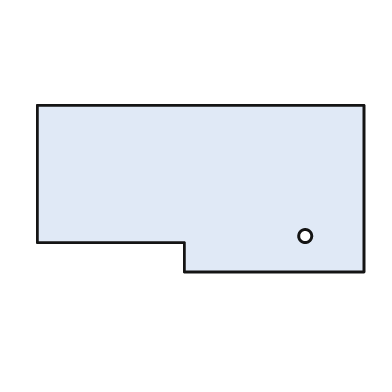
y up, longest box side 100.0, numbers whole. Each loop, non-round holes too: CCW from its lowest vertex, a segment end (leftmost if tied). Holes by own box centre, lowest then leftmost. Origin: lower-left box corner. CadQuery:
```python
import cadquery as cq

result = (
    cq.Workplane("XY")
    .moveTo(45.0, 0.0)
    .lineTo(100.0, 0.0)
    .lineTo(100.0, 51.0)
    .lineTo(0.0, 51.0)
    .lineTo(0.0, 9.0)
    .lineTo(45.0, 9.0)
    .close()
    .moveTo(82.0, 11.0)
    .circle(2.0)
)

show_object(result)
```